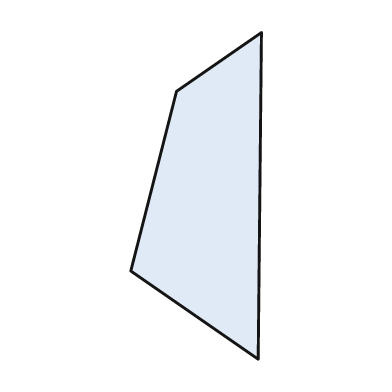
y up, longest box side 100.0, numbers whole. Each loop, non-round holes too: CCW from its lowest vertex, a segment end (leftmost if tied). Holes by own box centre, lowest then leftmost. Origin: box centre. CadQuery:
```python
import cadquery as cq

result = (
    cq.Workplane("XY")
    .moveTo(19.0, -50.0)
    .lineTo(20.0, 50.0)
    .lineTo(-6.0, 32.0)
    .lineTo(-20.0, -23.0)
    .close()
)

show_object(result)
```